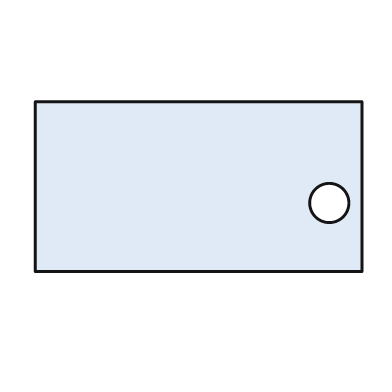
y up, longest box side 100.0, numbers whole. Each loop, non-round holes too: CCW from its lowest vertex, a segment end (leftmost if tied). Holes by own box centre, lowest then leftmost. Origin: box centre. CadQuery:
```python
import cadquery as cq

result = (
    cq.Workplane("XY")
    .moveTo(-50.0, -26.0)
    .lineTo(50.0, -26.0)
    .lineTo(50.0, 26.0)
    .lineTo(-50.0, 26.0)
    .close()
    .moveTo(40.0, -5.0)
    .circle(6.0)
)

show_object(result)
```